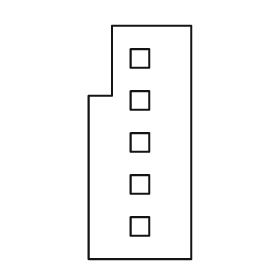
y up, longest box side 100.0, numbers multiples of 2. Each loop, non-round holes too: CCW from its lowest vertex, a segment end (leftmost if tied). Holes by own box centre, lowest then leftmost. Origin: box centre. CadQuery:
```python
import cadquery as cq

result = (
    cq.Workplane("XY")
    .moveTo(-22.0, -50.0)
    .lineTo(22.0, -50.0)
    .lineTo(22.0, 50.0)
    .lineTo(-12.0, 50.0)
    .lineTo(-12.0, 20.0)
    .lineTo(-22.0, 20.0)
    .close()
    .moveTo(-4.0, -40.0)
    .lineTo(4.0, -40.0)
    .lineTo(4.0, -32.0)
    .lineTo(-4.0, -32.0)
    .close()
    .moveTo(-4.0, -22.0)
    .lineTo(4.0, -22.0)
    .lineTo(4.0, -14.0)
    .lineTo(-4.0, -14.0)
    .close()
    .moveTo(-4.0, -4.0)
    .lineTo(4.0, -4.0)
    .lineTo(4.0, 4.0)
    .lineTo(-4.0, 4.0)
    .close()
    .moveTo(-4.0, 14.0)
    .lineTo(4.0, 14.0)
    .lineTo(4.0, 22.0)
    .lineTo(-4.0, 22.0)
    .close()
    .moveTo(-4.0, 32.0)
    .lineTo(4.0, 32.0)
    .lineTo(4.0, 40.0)
    .lineTo(-4.0, 40.0)
    .close()
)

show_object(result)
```